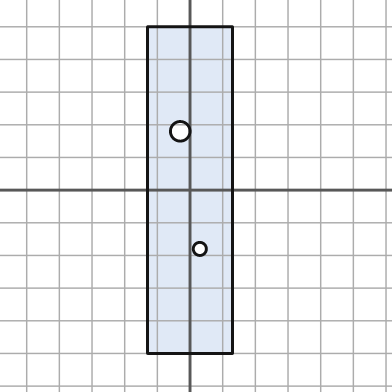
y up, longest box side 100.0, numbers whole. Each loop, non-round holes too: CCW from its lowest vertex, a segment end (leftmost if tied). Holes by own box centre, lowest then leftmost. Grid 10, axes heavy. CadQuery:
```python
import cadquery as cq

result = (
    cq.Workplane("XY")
    .moveTo(-13.0, -50.0)
    .lineTo(13.0, -50.0)
    .lineTo(13.0, 50.0)
    .lineTo(-13.0, 50.0)
    .close()
    .moveTo(3.0, -18.0)
    .circle(2.0)
    .moveTo(-3.0, 18.0)
    .circle(3.0)
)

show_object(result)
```